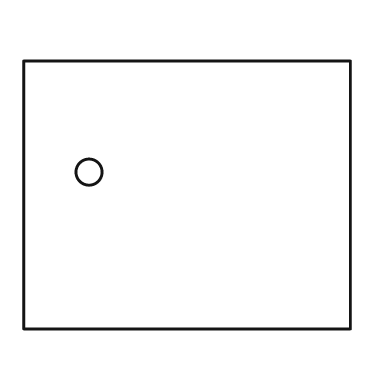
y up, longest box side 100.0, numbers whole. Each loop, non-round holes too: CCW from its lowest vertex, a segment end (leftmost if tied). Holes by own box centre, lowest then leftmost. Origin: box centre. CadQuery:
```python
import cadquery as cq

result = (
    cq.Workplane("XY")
    .moveTo(-50.0, -41.0)
    .lineTo(50.0, -41.0)
    .lineTo(50.0, 41.0)
    .lineTo(-50.0, 41.0)
    .close()
    .moveTo(-30.0, 7.0)
    .circle(4.0)
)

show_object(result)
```